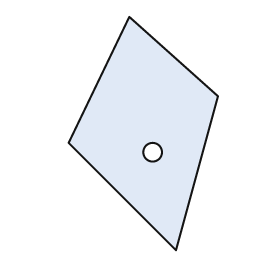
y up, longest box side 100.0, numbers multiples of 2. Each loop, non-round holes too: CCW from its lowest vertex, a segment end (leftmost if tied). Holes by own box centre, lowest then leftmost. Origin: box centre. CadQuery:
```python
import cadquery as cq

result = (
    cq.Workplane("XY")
    .moveTo(14.0, -50.0)
    .lineTo(32.0, 16.0)
    .lineTo(-6.0, 50.0)
    .lineTo(-32.0, -4.0)
    .close()
    .moveTo(4.0, -8.0)
    .circle(4.0)
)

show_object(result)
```